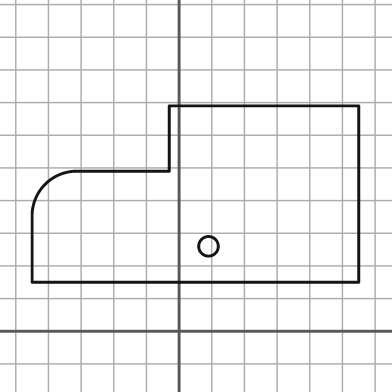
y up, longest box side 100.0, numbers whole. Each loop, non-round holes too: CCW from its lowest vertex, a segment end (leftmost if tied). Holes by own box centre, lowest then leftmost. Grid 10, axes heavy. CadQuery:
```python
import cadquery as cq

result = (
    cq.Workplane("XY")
    .moveTo(-45.0, 15.0)
    .lineTo(55.0, 15.0)
    .lineTo(55.0, 69.0)
    .lineTo(-3.0, 69.0)
    .lineTo(-3.0, 49.0)
    .lineTo(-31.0, 49.0)
    .threePointArc((-41.0, 45.0), (-45.0, 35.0))
    .close()
    .moveTo(9.0, 26.0)
    .circle(3.0)
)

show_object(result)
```